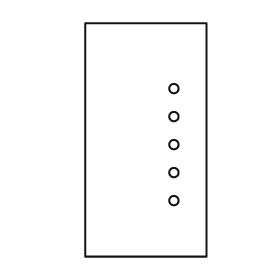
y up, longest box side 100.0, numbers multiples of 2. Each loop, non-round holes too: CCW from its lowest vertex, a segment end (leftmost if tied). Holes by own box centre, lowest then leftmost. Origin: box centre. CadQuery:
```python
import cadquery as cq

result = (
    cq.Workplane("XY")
    .moveTo(-26.0, -50.0)
    .lineTo(26.0, -50.0)
    .lineTo(26.0, 50.0)
    .lineTo(-26.0, 50.0)
    .close()
    .moveTo(12.0, -26.0)
    .circle(2.0)
    .moveTo(12.0, -14.0)
    .circle(2.0)
    .moveTo(12.0, -2.0)
    .circle(2.0)
    .moveTo(12.0, 10.0)
    .circle(2.0)
    .moveTo(12.0, 22.0)
    .circle(2.0)
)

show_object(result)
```